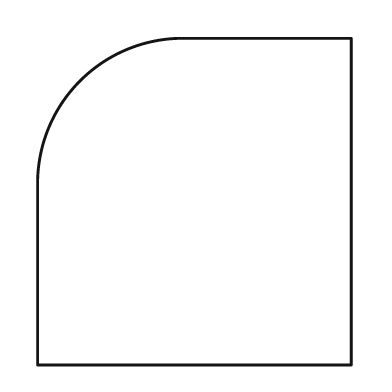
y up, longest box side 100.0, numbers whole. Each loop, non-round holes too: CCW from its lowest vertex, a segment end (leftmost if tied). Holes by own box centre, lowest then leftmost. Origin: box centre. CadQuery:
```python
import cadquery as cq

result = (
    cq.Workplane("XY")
    .moveTo(-48.0, -50.0)
    .lineTo(48.0, -50.0)
    .lineTo(48.0, 50.0)
    .lineTo(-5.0, 50.0)
    .threePointArc((-35.0, 37.0), (-48.0, 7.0))
    .close()
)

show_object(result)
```